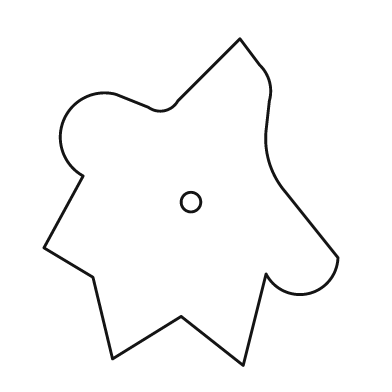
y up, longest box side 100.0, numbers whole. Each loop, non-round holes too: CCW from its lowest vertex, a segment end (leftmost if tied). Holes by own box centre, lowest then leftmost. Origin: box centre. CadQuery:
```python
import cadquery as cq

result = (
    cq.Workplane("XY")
    .moveTo(16.0, -50.0)
    .lineTo(23.0, -22.0)
    .threePointArc((36.0, -28.0), (45.0, -17.0))
    .lineTo(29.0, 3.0)
    .threePointArc((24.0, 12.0), (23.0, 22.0))
    .lineTo(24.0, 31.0)
    .threePointArc((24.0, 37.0), (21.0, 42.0))
    .lineTo(15.0, 50.0)
    .lineTo(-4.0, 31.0)
    .threePointArc((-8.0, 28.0), (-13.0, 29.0))
    .lineTo(-23.0, 33.0)
    .threePointArc((-39.0, 25.0), (-33.0, 8.0))
    .lineTo(-45.0, -14.0)
    .lineTo(-30.0, -23.0)
    .lineTo(-24.0, -48.0)
    .lineTo(-3.0, -35.0)
    .close()
    .moveTo(0.0, 0.0)
    .circle(3.0)
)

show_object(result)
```